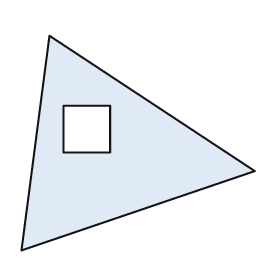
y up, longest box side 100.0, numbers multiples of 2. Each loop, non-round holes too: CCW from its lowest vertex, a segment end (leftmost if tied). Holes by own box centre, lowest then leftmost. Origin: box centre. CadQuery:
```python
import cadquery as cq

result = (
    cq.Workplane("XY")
    .moveTo(-50.0, -46.0)
    .lineTo(50.0, -12.0)
    .lineTo(-38.0, 46.0)
    .close()
    .moveTo(-32.0, -4.0)
    .lineTo(-12.0, -4.0)
    .lineTo(-12.0, 16.0)
    .lineTo(-32.0, 16.0)
    .close()
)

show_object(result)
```